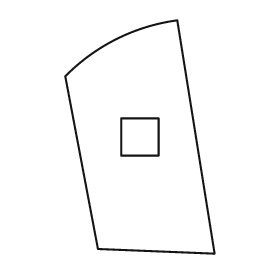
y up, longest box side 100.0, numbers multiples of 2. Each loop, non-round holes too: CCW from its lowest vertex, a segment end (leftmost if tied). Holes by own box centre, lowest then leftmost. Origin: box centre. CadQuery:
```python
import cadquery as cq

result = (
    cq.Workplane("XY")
    .moveTo(32.0, -50.0)
    .lineTo(16.0, 50.0)
    .threePointArc((-10.0, 42.0), (-32.0, 26.0))
    .lineTo(-18.0, -48.0)
    .close()
    .moveTo(-8.0, -8.0)
    .lineTo(8.0, -8.0)
    .lineTo(8.0, 8.0)
    .lineTo(-8.0, 8.0)
    .close()
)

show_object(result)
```